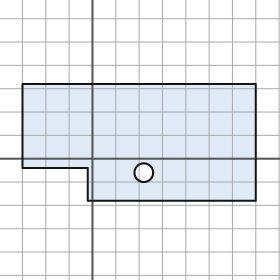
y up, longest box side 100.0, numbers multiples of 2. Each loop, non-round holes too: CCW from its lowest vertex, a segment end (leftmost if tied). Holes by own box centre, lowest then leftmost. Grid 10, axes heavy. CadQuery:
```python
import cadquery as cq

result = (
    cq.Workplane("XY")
    .moveTo(-2.0, -18.0)
    .lineTo(70.0, -18.0)
    .lineTo(70.0, 32.0)
    .lineTo(-30.0, 32.0)
    .lineTo(-30.0, -4.0)
    .lineTo(-2.0, -4.0)
    .close()
    .moveTo(22.0, -6.0)
    .circle(4.0)
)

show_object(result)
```